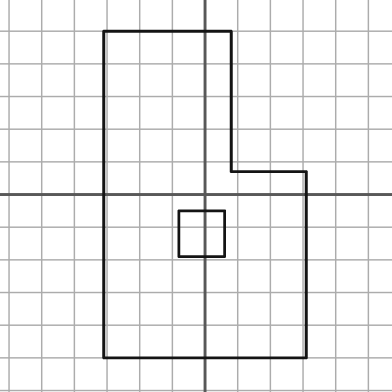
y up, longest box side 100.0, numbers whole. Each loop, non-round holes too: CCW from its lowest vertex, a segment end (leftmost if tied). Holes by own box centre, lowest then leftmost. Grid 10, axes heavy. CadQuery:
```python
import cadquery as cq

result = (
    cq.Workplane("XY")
    .moveTo(-31.0, -50.0)
    .lineTo(31.0, -50.0)
    .lineTo(31.0, 7.0)
    .lineTo(8.0, 7.0)
    .lineTo(8.0, 50.0)
    .lineTo(-31.0, 50.0)
    .close()
    .moveTo(-8.0, -19.0)
    .lineTo(6.0, -19.0)
    .lineTo(6.0, -5.0)
    .lineTo(-8.0, -5.0)
    .close()
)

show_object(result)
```